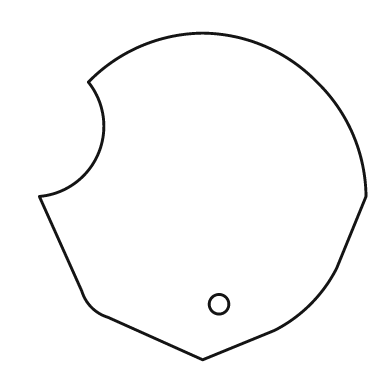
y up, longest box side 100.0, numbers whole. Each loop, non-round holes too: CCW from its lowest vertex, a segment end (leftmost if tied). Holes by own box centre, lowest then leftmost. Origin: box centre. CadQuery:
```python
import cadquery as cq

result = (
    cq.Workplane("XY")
    .moveTo(0.0, -50.0)
    .lineTo(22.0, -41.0)
    .threePointArc((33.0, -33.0), (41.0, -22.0))
    .lineTo(50.0, 0.0)
    .threePointArc((46.0, 19.0), (35.0, 35.0))
    .threePointArc((19.0, 46.0), (0.0, 50.0))
    .threePointArc((-19.0, 46.0), (-35.0, 35.0))
    .threePointArc((-32.0, 13.0), (-50.0, 0.0))
    .lineTo(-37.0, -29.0)
    .threePointArc((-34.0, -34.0), (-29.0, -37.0))
    .close()
    .moveTo(5.0, -33.0)
    .circle(3.0)
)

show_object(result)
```